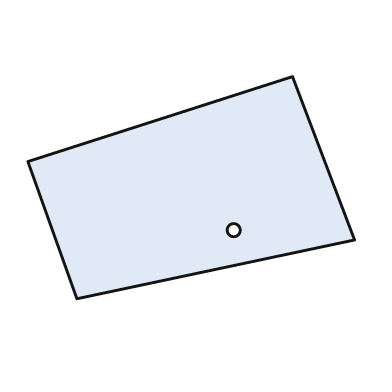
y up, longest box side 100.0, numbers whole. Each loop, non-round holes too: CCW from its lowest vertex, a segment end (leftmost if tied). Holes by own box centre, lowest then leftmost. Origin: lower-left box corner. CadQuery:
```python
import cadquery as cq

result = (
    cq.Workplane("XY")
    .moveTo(15.0, 0.0)
    .lineTo(100.0, 18.0)
    .lineTo(81.0, 68.0)
    .lineTo(0.0, 42.0)
    .close()
    .moveTo(63.0, 21.0)
    .circle(2.0)
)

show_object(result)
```